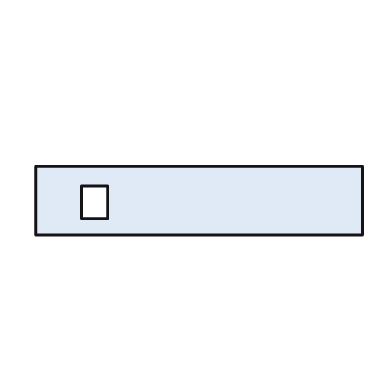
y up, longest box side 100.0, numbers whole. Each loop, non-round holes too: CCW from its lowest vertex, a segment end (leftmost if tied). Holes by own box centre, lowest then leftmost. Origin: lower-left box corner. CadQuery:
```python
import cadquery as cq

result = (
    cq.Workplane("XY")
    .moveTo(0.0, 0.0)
    .lineTo(100.0, 0.0)
    .lineTo(100.0, 21.0)
    .lineTo(0.0, 21.0)
    .close()
    .moveTo(14.0, 5.0)
    .lineTo(22.0, 5.0)
    .lineTo(22.0, 15.0)
    .lineTo(14.0, 15.0)
    .close()
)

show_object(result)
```